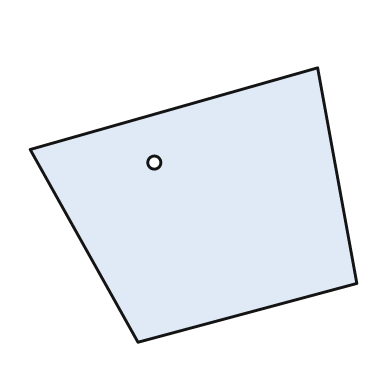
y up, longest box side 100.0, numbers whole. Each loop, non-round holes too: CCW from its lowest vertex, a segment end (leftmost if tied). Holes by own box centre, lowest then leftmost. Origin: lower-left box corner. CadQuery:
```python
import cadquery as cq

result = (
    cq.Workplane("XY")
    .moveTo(33.0, 0.0)
    .lineTo(100.0, 18.0)
    .lineTo(88.0, 84.0)
    .lineTo(0.0, 59.0)
    .close()
    .moveTo(38.0, 55.0)
    .circle(2.0)
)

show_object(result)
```